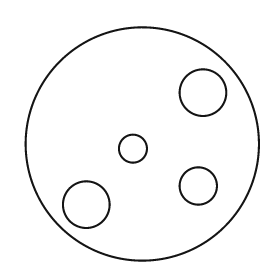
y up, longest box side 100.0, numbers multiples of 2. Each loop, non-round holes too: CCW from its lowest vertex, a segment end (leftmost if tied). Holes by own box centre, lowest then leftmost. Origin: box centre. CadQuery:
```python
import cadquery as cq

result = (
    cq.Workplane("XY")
    .moveTo(0.0, 0.0)
    .circle(50.0)
    .moveTo(-24.0, -26.0)
    .circle(10.0)
    .moveTo(24.0, -18.0)
    .circle(8.0)
    .moveTo(-4.0, -2.0)
    .circle(6.0)
    .moveTo(26.0, 22.0)
    .circle(10.0)
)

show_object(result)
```